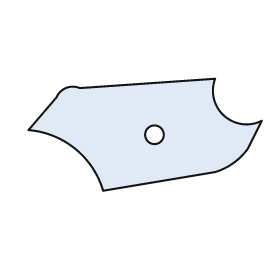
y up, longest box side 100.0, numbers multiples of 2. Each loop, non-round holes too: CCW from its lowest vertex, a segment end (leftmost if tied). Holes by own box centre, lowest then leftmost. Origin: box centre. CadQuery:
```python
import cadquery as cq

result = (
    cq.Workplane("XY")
    .moveTo(-18.0, -24.0)
    .lineTo(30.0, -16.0)
    .threePointArc((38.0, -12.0), (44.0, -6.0))
    .lineTo(50.0, 6.0)
    .threePointArc((34.0, 8.0), (30.0, 24.0))
    .lineTo(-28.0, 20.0)
    .threePointArc((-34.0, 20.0), (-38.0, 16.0))
    .lineTo(-50.0, 2.0)
    .threePointArc((-30.0, -6.0), (-18.0, -24.0))
    .close()
    .moveTo(4.0, 0.0)
    .circle(4.0)
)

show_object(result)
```